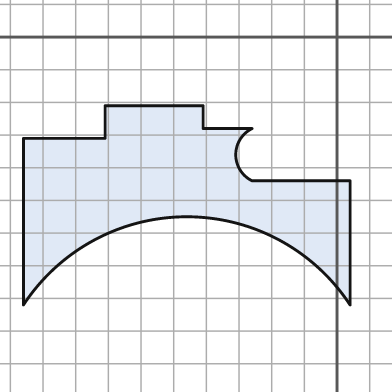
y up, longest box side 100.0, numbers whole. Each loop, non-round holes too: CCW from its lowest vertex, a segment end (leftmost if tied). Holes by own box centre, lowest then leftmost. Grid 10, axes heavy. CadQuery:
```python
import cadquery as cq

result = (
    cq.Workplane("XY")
    .moveTo(-96.0, -82.0)
    .threePointArc((-46.0, -55.0), (4.0, -82.0))
    .lineTo(4.0, -44.0)
    .lineTo(-26.0, -44.0)
    .threePointArc((-31.0, -36.0), (-26.0, -28.0))
    .lineTo(-41.0, -28.0)
    .lineTo(-41.0, -21.0)
    .lineTo(-71.0, -21.0)
    .lineTo(-71.0, -31.0)
    .lineTo(-96.0, -31.0)
    .close()
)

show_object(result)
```